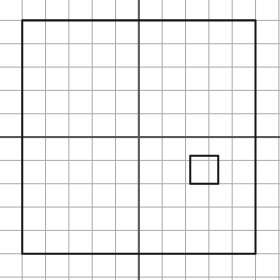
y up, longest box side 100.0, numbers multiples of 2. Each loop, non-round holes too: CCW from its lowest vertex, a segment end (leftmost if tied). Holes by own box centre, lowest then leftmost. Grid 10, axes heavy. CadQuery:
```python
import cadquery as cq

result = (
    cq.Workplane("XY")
    .moveTo(-50.0, -50.0)
    .lineTo(50.0, -50.0)
    .lineTo(50.0, 50.0)
    .lineTo(-50.0, 50.0)
    .close()
    .moveTo(22.0, -20.0)
    .lineTo(34.0, -20.0)
    .lineTo(34.0, -8.0)
    .lineTo(22.0, -8.0)
    .close()
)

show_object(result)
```